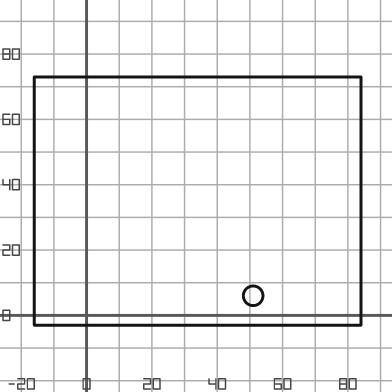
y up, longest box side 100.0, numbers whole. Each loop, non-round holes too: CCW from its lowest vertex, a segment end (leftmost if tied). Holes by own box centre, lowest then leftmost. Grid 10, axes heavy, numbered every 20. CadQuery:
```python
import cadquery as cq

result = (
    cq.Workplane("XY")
    .moveTo(-16.0, -3.0)
    .lineTo(84.0, -3.0)
    .lineTo(84.0, 73.0)
    .lineTo(-16.0, 73.0)
    .close()
    .moveTo(51.0, 6.0)
    .circle(3.0)
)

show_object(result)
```